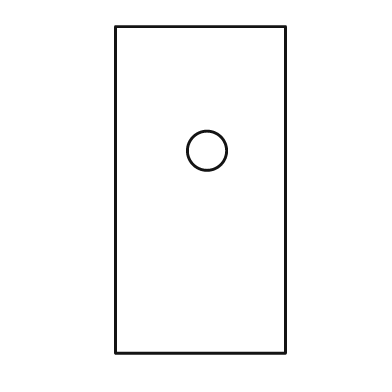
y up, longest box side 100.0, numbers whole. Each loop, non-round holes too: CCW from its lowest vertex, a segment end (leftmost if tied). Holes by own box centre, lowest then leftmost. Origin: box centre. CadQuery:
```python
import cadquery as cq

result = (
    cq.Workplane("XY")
    .moveTo(-26.0, -50.0)
    .lineTo(26.0, -50.0)
    .lineTo(26.0, 50.0)
    .lineTo(-26.0, 50.0)
    .close()
    .moveTo(2.0, 12.0)
    .circle(6.0)
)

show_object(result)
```